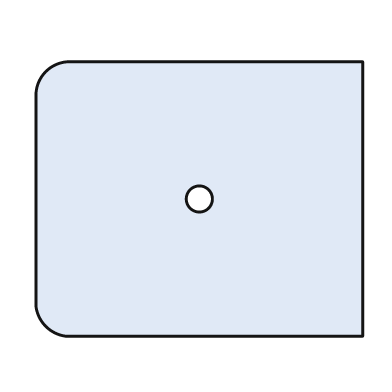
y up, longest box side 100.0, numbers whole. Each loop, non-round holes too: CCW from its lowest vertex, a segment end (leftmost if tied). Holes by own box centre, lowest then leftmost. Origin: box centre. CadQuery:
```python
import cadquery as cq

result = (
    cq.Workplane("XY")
    .moveTo(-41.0, -42.0)
    .lineTo(50.0, -42.0)
    .lineTo(50.0, 42.0)
    .lineTo(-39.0, 42.0)
    .threePointArc((-47.0, 39.0), (-50.0, 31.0))
    .lineTo(-50.0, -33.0)
    .threePointArc((-47.0, -39.0), (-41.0, -42.0))
    .close()
    .moveTo(0.0, 0.0)
    .circle(4.0)
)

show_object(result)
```